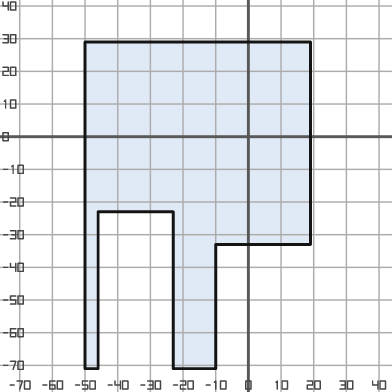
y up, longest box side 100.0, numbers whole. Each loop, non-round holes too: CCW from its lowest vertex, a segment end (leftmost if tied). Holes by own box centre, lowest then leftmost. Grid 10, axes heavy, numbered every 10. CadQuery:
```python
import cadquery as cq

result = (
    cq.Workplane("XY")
    .moveTo(-50.0, -71.0)
    .lineTo(-46.0, -71.0)
    .lineTo(-46.0, -23.0)
    .lineTo(-23.0, -23.0)
    .lineTo(-23.0, -71.0)
    .lineTo(-10.0, -71.0)
    .lineTo(-10.0, -33.0)
    .lineTo(19.0, -33.0)
    .lineTo(19.0, 29.0)
    .lineTo(-50.0, 29.0)
    .close()
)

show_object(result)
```